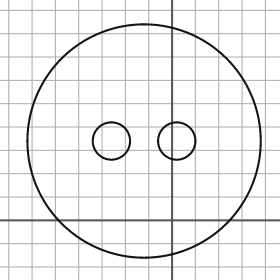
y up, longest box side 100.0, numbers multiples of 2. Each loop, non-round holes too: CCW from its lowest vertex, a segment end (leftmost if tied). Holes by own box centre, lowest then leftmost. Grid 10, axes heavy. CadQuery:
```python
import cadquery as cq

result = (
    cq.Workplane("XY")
    .moveTo(-12.0, 34.0)
    .circle(50.0)
    .moveTo(-26.0, 34.0)
    .circle(8.0)
    .moveTo(2.0, 34.0)
    .circle(8.0)
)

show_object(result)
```